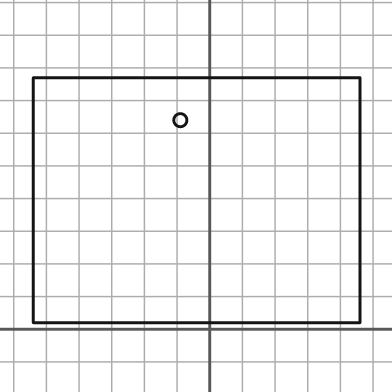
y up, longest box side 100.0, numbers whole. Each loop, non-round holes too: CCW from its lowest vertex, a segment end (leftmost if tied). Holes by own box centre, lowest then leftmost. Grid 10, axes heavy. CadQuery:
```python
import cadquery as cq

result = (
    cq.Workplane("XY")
    .moveTo(-54.0, 2.0)
    .lineTo(46.0, 2.0)
    .lineTo(46.0, 77.0)
    .lineTo(-54.0, 77.0)
    .close()
    .moveTo(-9.0, 64.0)
    .circle(2.0)
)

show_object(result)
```